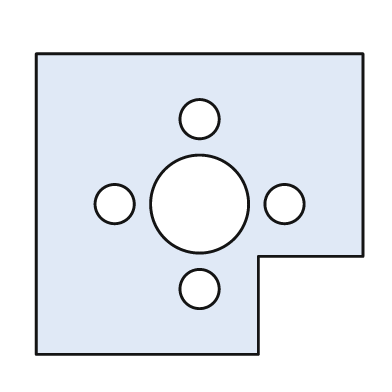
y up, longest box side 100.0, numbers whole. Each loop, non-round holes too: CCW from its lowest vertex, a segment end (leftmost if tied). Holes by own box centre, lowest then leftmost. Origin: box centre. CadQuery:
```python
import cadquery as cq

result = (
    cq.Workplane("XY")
    .moveTo(-50.0, -46.0)
    .lineTo(18.0, -46.0)
    .lineTo(18.0, -16.0)
    .lineTo(50.0, -16.0)
    .lineTo(50.0, 46.0)
    .lineTo(-50.0, 46.0)
    .close()
    .moveTo(0.0, -26.0)
    .circle(6.0)
    .moveTo(-26.0, 0.0)
    .circle(6.0)
    .moveTo(0.0, 0.0)
    .circle(15.0)
    .moveTo(26.0, 0.0)
    .circle(6.0)
    .moveTo(0.0, 26.0)
    .circle(6.0)
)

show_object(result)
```